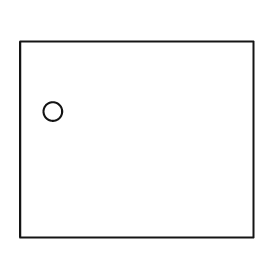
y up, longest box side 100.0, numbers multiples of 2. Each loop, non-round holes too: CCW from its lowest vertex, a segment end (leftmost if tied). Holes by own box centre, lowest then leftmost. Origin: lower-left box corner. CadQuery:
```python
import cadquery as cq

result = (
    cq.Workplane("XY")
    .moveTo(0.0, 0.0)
    .lineTo(100.0, 0.0)
    .lineTo(100.0, 84.0)
    .lineTo(0.0, 84.0)
    .close()
    .moveTo(14.0, 54.0)
    .circle(4.0)
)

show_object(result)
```